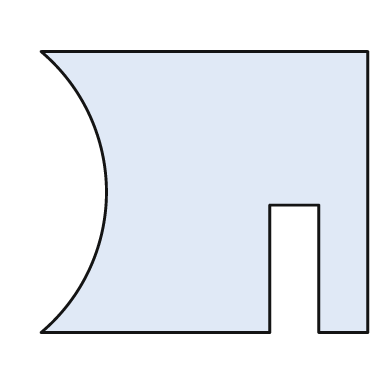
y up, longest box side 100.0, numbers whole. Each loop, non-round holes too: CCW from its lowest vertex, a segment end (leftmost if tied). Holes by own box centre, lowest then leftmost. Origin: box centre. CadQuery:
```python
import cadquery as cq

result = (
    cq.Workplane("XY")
    .moveTo(-50.0, -43.0)
    .lineTo(20.0, -43.0)
    .lineTo(20.0, -4.0)
    .lineTo(35.0, -4.0)
    .lineTo(35.0, -43.0)
    .lineTo(50.0, -43.0)
    .lineTo(50.0, 43.0)
    .lineTo(-50.0, 43.0)
    .threePointArc((-30.0, 0.0), (-50.0, -43.0))
    .close()
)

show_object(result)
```